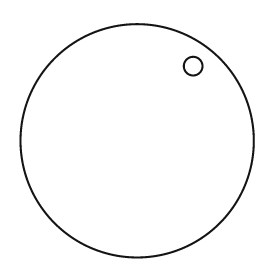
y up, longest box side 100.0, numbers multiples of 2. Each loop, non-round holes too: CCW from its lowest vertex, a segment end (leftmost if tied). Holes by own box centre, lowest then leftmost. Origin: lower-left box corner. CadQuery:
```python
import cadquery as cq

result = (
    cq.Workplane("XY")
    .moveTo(50.0, 50.0)
    .circle(50.0)
    .moveTo(74.0, 82.0)
    .circle(4.0)
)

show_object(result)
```